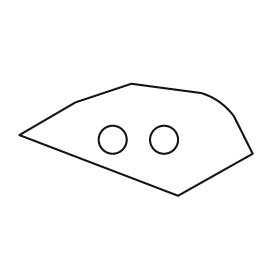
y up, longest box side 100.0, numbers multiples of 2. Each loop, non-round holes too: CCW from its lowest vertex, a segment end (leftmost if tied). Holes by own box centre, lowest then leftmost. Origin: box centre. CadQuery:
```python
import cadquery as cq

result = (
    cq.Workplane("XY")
    .moveTo(18.0, -24.0)
    .lineTo(50.0, -6.0)
    .lineTo(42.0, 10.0)
    .threePointArc((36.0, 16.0), (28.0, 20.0))
    .lineTo(-2.0, 24.0)
    .lineTo(-26.0, 16.0)
    .lineTo(-50.0, 2.0)
    .close()
    .moveTo(-10.0, 0.0)
    .circle(6.0)
    .moveTo(12.0, 0.0)
    .circle(6.0)
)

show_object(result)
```